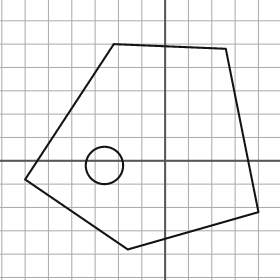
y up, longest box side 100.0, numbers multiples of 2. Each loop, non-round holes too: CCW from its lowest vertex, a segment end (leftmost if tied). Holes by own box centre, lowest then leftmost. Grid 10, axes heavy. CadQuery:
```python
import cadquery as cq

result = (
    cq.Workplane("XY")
    .moveTo(-16.0, -38.0)
    .lineTo(40.0, -22.0)
    .lineTo(26.0, 48.0)
    .lineTo(-22.0, 50.0)
    .lineTo(-60.0, -8.0)
    .close()
    .moveTo(-26.0, -2.0)
    .circle(8.0)
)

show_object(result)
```